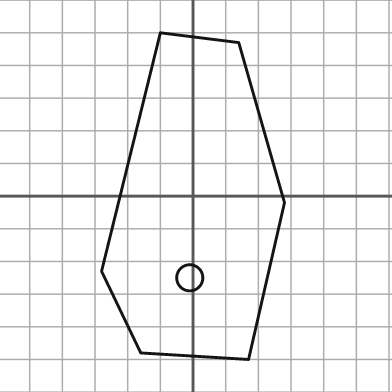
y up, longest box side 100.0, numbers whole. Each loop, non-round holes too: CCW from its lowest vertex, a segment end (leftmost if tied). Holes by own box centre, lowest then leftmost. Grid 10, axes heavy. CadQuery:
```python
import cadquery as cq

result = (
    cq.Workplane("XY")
    .moveTo(17.0, -50.0)
    .lineTo(28.0, -2.0)
    .lineTo(14.0, 47.0)
    .lineTo(-10.0, 50.0)
    .lineTo(-28.0, -23.0)
    .lineTo(-16.0, -48.0)
    .close()
    .moveTo(-1.0, -25.0)
    .circle(4.0)
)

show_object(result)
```